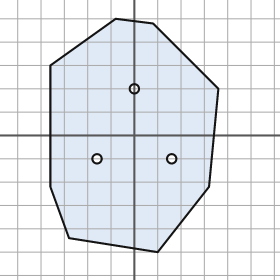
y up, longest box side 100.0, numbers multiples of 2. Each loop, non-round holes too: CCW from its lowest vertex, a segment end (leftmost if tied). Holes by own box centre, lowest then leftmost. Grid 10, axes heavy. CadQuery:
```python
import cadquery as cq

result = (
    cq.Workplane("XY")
    .moveTo(10.0, -50.0)
    .lineTo(32.0, -22.0)
    .lineTo(36.0, 20.0)
    .lineTo(8.0, 48.0)
    .lineTo(-8.0, 50.0)
    .lineTo(-36.0, 30.0)
    .lineTo(-36.0, -22.0)
    .lineTo(-28.0, -44.0)
    .close()
    .moveTo(-16.0, -10.0)
    .circle(2.0)
    .moveTo(16.0, -10.0)
    .circle(2.0)
    .moveTo(0.0, 20.0)
    .circle(2.0)
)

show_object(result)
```